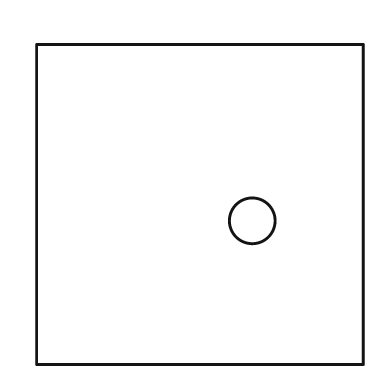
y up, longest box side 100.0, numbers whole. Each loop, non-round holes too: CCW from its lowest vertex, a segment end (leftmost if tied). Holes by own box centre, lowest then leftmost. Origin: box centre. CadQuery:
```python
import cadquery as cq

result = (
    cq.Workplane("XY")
    .moveTo(-50.0, -49.0)
    .lineTo(50.0, -49.0)
    .lineTo(50.0, 49.0)
    .lineTo(-50.0, 49.0)
    .close()
    .moveTo(16.0, -5.0)
    .circle(7.0)
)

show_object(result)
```